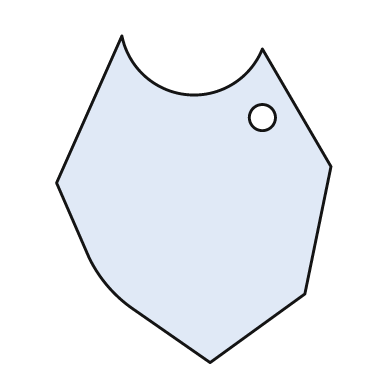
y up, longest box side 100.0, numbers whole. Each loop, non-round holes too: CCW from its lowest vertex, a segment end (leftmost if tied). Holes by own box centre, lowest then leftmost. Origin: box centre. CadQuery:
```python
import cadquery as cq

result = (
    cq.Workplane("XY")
    .moveTo(5.0, -50.0)
    .lineTo(34.0, -29.0)
    .lineTo(42.0, 10.0)
    .lineTo(21.0, 46.0)
    .threePointArc((-2.0, 32.0), (-22.0, 50.0))
    .lineTo(-42.0, 5.0)
    .lineTo(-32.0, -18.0)
    .threePointArc((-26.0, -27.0), (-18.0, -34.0))
    .close()
    .moveTo(21.0, 25.0)
    .circle(4.0)
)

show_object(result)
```